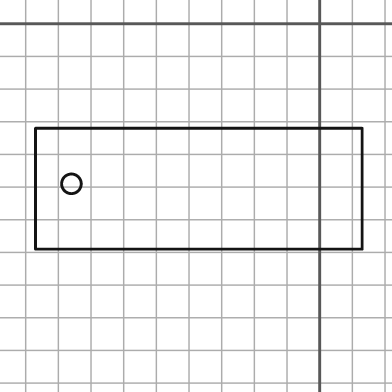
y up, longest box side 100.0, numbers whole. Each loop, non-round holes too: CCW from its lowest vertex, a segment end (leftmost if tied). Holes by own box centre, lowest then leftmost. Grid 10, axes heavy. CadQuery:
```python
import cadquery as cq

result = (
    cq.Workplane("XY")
    .moveTo(-87.0, -69.0)
    .lineTo(13.0, -69.0)
    .lineTo(13.0, -32.0)
    .lineTo(-87.0, -32.0)
    .close()
    .moveTo(-76.0, -49.0)
    .circle(3.0)
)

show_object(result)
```